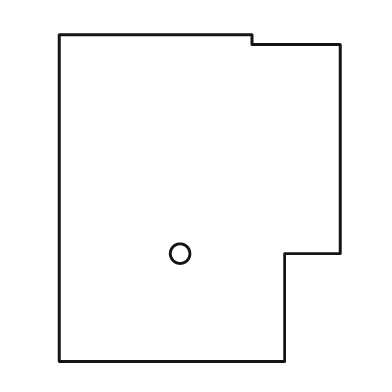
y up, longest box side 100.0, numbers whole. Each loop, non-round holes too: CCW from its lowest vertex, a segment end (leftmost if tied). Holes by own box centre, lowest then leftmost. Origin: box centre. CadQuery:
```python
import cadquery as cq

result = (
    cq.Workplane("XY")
    .moveTo(-43.0, -50.0)
    .lineTo(26.0, -50.0)
    .lineTo(26.0, -17.0)
    .lineTo(43.0, -17.0)
    .lineTo(43.0, 47.0)
    .lineTo(16.0, 47.0)
    .lineTo(16.0, 50.0)
    .lineTo(-43.0, 50.0)
    .close()
    .moveTo(-6.0, -17.0)
    .circle(3.0)
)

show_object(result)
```